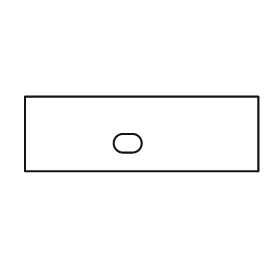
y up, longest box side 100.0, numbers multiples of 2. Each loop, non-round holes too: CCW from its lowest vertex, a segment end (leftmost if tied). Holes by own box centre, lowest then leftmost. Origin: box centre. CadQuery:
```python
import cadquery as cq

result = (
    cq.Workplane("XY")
    .moveTo(-50.0, -16.0)
    .lineTo(50.0, -16.0)
    .lineTo(50.0, 16.0)
    .lineTo(-50.0, 16.0)
    .close()
    .moveTo(-8.0, -8.0)
    .lineTo(-4.0, -8.0)
    .threePointArc((0.0, -4.0), (-4.0, 0.0))
    .lineTo(-8.0, 0.0)
    .threePointArc((-12.0, -4.0), (-8.0, -8.0))
    .close()
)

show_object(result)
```